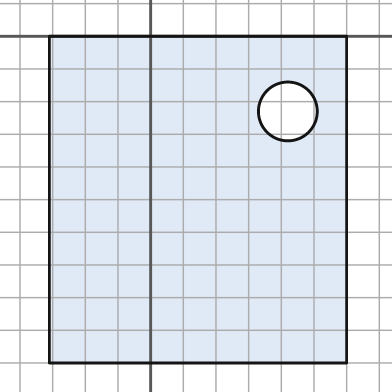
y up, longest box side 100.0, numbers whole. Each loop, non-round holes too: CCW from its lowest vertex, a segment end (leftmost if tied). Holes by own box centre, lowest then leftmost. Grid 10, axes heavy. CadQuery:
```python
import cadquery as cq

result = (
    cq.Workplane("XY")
    .moveTo(-31.0, -100.0)
    .lineTo(60.0, -100.0)
    .lineTo(60.0, 0.0)
    .lineTo(-31.0, 0.0)
    .close()
    .moveTo(42.0, -23.0)
    .circle(9.0)
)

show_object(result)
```